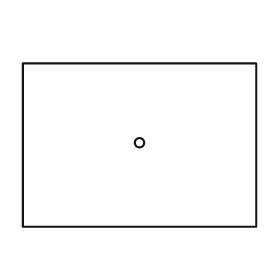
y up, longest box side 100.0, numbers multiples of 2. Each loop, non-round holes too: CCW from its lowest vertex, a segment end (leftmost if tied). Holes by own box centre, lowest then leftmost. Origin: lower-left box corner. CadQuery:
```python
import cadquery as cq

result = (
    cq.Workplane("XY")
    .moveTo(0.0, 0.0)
    .lineTo(100.0, 0.0)
    .lineTo(100.0, 70.0)
    .lineTo(0.0, 70.0)
    .close()
    .moveTo(50.0, 36.0)
    .circle(2.0)
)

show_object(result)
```